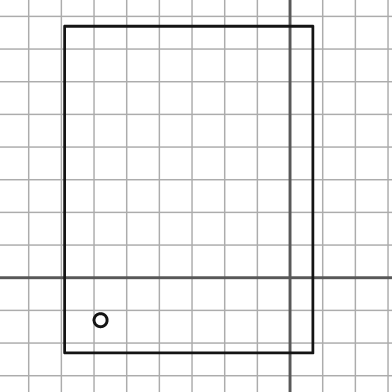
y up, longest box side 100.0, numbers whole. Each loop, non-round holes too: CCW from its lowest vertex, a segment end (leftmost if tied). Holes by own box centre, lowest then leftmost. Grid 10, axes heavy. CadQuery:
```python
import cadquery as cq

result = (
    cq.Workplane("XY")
    .moveTo(-69.0, -23.0)
    .lineTo(7.0, -23.0)
    .lineTo(7.0, 77.0)
    .lineTo(-69.0, 77.0)
    .close()
    .moveTo(-58.0, -13.0)
    .circle(2.0)
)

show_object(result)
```